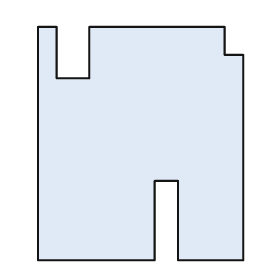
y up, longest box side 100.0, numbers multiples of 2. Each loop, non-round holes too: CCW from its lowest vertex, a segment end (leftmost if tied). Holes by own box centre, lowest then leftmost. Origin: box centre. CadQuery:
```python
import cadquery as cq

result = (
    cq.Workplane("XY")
    .moveTo(-44.0, -50.0)
    .lineTo(6.0, -50.0)
    .lineTo(6.0, -16.0)
    .lineTo(16.0, -16.0)
    .lineTo(16.0, -50.0)
    .lineTo(44.0, -50.0)
    .lineTo(44.0, 38.0)
    .lineTo(36.0, 38.0)
    .lineTo(36.0, 50.0)
    .lineTo(-22.0, 50.0)
    .lineTo(-22.0, 28.0)
    .lineTo(-36.0, 28.0)
    .lineTo(-36.0, 50.0)
    .lineTo(-44.0, 50.0)
    .close()
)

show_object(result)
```